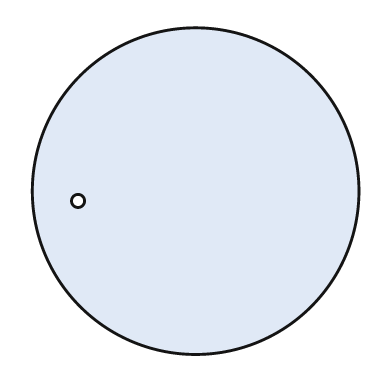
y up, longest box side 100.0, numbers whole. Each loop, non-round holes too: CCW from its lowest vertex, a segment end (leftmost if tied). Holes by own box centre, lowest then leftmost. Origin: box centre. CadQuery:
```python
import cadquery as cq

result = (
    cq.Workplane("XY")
    .moveTo(0.0, 0.0)
    .circle(50.0)
    .moveTo(-36.0, -3.0)
    .circle(2.0)
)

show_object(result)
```